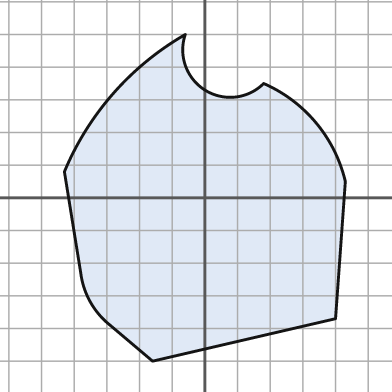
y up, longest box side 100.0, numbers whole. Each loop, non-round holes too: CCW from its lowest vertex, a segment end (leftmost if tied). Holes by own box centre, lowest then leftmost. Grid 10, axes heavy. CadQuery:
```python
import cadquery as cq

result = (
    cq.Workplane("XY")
    .moveTo(-16.0, -50.0)
    .lineTo(40.0, -37.0)
    .lineTo(43.0, 5.0)
    .threePointArc((34.0, 23.0), (18.0, 35.0))
    .threePointArc((0.0, 33.0), (-6.0, 50.0))
    .threePointArc((-28.0, 32.0), (-43.0, 8.0))
    .lineTo(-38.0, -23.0)
    .threePointArc((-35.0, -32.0), (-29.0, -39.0))
    .close()
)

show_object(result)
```